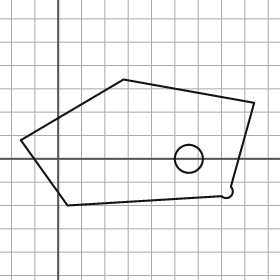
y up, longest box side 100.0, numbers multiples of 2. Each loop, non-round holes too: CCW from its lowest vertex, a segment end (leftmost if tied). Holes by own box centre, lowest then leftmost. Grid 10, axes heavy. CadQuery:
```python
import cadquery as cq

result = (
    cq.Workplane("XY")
    .moveTo(4.0, -20.0)
    .lineTo(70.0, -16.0)
    .threePointArc((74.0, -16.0), (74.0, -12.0))
    .lineTo(84.0, 24.0)
    .lineTo(28.0, 34.0)
    .lineTo(-16.0, 8.0)
    .close()
    .moveTo(56.0, 0.0)
    .circle(6.0)
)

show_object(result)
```